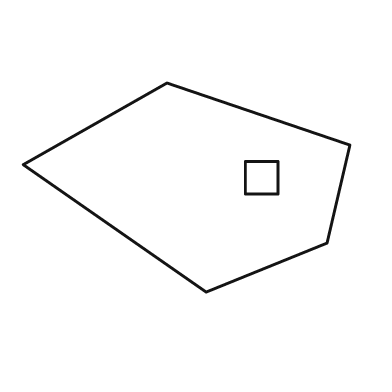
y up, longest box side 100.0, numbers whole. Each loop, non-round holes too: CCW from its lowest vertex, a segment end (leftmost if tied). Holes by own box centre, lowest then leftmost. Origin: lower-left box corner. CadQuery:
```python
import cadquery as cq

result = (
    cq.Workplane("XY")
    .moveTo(56.0, 0.0)
    .lineTo(93.0, 15.0)
    .lineTo(100.0, 45.0)
    .lineTo(44.0, 64.0)
    .lineTo(0.0, 39.0)
    .close()
    .moveTo(68.0, 30.0)
    .lineTo(78.0, 30.0)
    .lineTo(78.0, 40.0)
    .lineTo(68.0, 40.0)
    .close()
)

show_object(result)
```